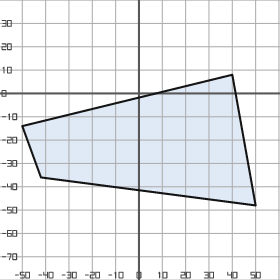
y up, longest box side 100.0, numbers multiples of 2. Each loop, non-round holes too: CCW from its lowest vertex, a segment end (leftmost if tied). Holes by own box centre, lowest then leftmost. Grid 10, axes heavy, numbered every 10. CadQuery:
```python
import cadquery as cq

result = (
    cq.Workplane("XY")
    .moveTo(50.0, -48.0)
    .lineTo(40.0, 8.0)
    .lineTo(-50.0, -14.0)
    .lineTo(-42.0, -36.0)
    .close()
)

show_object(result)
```